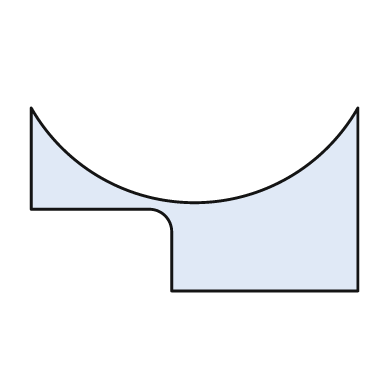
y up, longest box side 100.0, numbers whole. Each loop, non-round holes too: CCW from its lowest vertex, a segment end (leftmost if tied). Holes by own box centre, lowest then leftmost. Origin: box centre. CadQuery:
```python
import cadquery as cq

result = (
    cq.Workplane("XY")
    .moveTo(-7.0, -28.0)
    .lineTo(50.0, -28.0)
    .lineTo(50.0, 28.0)
    .threePointArc((0.0, -1.0), (-50.0, 28.0))
    .lineTo(-50.0, -3.0)
    .lineTo(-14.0, -3.0)
    .threePointArc((-9.0, -5.0), (-7.0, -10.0))
    .close()
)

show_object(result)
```